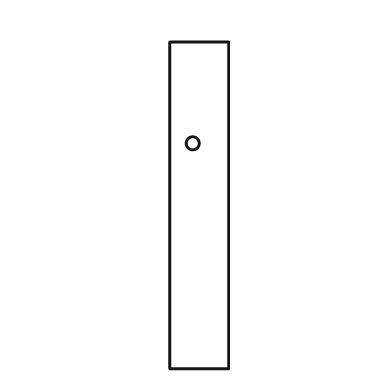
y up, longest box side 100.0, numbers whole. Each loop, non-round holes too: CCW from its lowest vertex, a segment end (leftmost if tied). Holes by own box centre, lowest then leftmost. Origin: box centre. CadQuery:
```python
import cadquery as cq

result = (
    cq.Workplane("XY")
    .moveTo(-9.0, -50.0)
    .lineTo(9.0, -50.0)
    .lineTo(9.0, 50.0)
    .lineTo(-9.0, 50.0)
    .close()
    .moveTo(-2.0, 19.0)
    .circle(2.0)
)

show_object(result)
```